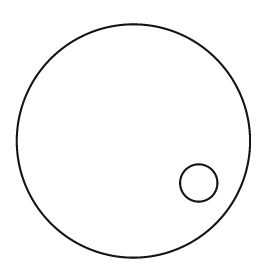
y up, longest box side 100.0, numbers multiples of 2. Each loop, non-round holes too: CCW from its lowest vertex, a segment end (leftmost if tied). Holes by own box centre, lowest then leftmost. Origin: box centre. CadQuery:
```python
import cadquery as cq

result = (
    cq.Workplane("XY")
    .moveTo(0.0, 0.0)
    .circle(50.0)
    .moveTo(28.0, -18.0)
    .circle(8.0)
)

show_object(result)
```